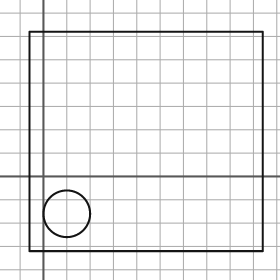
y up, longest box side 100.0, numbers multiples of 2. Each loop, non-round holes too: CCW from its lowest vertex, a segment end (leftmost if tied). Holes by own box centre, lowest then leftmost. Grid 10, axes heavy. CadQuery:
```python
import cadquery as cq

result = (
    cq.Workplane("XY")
    .moveTo(-6.0, -32.0)
    .lineTo(94.0, -32.0)
    .lineTo(94.0, 62.0)
    .lineTo(-6.0, 62.0)
    .close()
    .moveTo(10.0, -16.0)
    .circle(10.0)
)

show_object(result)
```